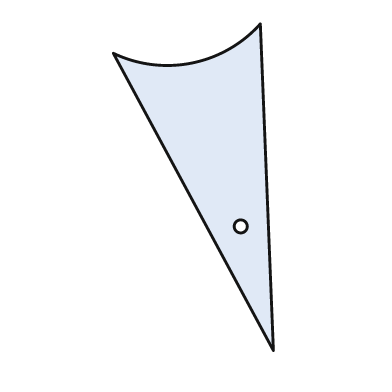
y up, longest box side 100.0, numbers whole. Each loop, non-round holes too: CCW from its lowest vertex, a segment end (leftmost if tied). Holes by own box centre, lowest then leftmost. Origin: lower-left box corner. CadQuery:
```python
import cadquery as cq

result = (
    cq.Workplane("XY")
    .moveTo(49.0, 0.0)
    .lineTo(45.0, 100.0)
    .threePointArc((24.0, 88.0), (0.0, 91.0))
    .close()
    .moveTo(39.0, 38.0)
    .circle(2.0)
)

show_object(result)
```